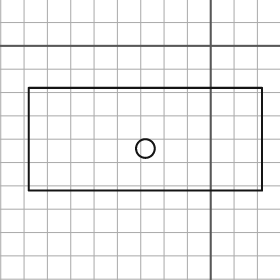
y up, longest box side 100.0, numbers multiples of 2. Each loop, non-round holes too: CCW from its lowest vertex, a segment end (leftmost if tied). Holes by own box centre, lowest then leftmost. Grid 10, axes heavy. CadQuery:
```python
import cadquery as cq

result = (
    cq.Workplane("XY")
    .moveTo(-78.0, -62.0)
    .lineTo(22.0, -62.0)
    .lineTo(22.0, -18.0)
    .lineTo(-78.0, -18.0)
    .close()
    .moveTo(-28.0, -44.0)
    .circle(4.0)
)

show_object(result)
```